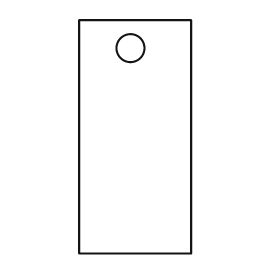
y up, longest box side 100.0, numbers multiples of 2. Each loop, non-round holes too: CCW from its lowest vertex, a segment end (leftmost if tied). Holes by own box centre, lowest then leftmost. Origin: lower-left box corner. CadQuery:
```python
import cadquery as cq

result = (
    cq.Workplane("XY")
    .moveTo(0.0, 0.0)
    .lineTo(48.0, 0.0)
    .lineTo(48.0, 100.0)
    .lineTo(0.0, 100.0)
    .close()
    .moveTo(22.0, 88.0)
    .circle(6.0)
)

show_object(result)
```